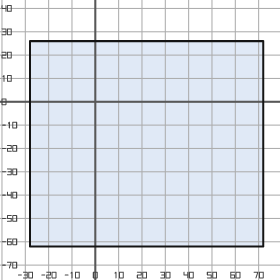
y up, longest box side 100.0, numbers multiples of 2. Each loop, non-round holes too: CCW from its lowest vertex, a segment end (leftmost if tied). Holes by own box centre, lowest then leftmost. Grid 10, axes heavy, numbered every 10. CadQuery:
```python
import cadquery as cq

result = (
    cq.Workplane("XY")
    .moveTo(-28.0, -62.0)
    .lineTo(72.0, -62.0)
    .lineTo(72.0, 26.0)
    .lineTo(-28.0, 26.0)
    .close()
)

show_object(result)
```